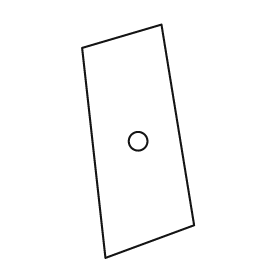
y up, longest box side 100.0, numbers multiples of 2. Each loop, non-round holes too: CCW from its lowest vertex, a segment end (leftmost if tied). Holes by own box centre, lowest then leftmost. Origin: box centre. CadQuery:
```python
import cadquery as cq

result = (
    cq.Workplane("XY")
    .moveTo(-14.0, -50.0)
    .lineTo(24.0, -36.0)
    .lineTo(10.0, 50.0)
    .lineTo(-24.0, 40.0)
    .close()
    .moveTo(0.0, 0.0)
    .circle(4.0)
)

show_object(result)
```